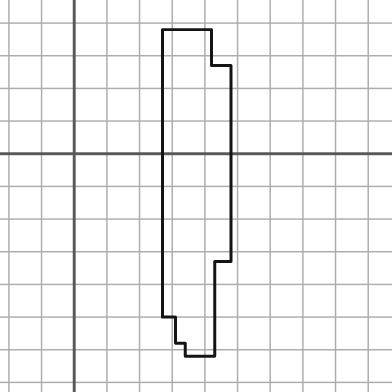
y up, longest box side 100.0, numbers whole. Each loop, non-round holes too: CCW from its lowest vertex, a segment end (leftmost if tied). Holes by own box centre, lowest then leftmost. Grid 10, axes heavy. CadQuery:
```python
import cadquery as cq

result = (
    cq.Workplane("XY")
    .moveTo(34.0, -62.0)
    .lineTo(43.0, -62.0)
    .lineTo(43.0, -33.0)
    .lineTo(48.0, -33.0)
    .lineTo(48.0, 27.0)
    .lineTo(42.0, 27.0)
    .lineTo(42.0, 38.0)
    .lineTo(27.0, 38.0)
    .lineTo(27.0, -50.0)
    .lineTo(31.0, -50.0)
    .lineTo(31.0, -58.0)
    .lineTo(34.0, -58.0)
    .close()
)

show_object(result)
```